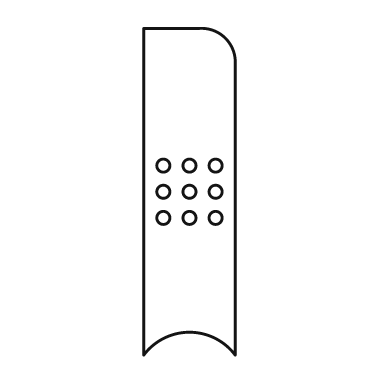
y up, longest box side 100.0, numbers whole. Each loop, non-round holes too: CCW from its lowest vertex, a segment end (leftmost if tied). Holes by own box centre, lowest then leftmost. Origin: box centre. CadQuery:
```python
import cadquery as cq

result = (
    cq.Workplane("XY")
    .moveTo(-14.0, -50.0)
    .threePointArc((0.0, -43.0), (14.0, -50.0))
    .lineTo(14.0, 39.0)
    .threePointArc((11.0, 47.0), (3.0, 50.0))
    .lineTo(-14.0, 50.0)
    .close()
    .moveTo(-8.0, -8.0)
    .circle(2.0)
    .moveTo(0.0, -8.0)
    .circle(2.0)
    .moveTo(8.0, -8.0)
    .circle(2.0)
    .moveTo(-8.0, 0.0)
    .circle(2.0)
    .moveTo(0.0, 0.0)
    .circle(2.0)
    .moveTo(8.0, 0.0)
    .circle(2.0)
    .moveTo(-8.0, 8.0)
    .circle(2.0)
    .moveTo(0.0, 8.0)
    .circle(2.0)
    .moveTo(8.0, 8.0)
    .circle(2.0)
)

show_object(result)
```